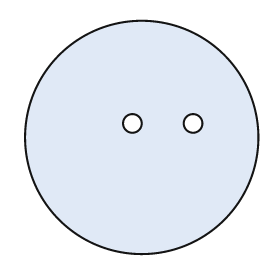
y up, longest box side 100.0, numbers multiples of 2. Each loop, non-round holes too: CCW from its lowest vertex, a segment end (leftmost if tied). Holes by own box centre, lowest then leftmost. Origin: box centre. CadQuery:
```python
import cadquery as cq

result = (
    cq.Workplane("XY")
    .moveTo(0.0, 0.0)
    .circle(50.0)
    .moveTo(-4.0, 6.0)
    .circle(4.0)
    .moveTo(22.0, 6.0)
    .circle(4.0)
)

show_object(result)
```